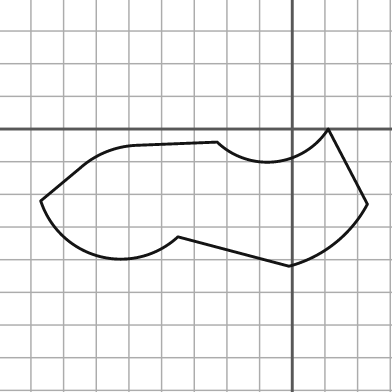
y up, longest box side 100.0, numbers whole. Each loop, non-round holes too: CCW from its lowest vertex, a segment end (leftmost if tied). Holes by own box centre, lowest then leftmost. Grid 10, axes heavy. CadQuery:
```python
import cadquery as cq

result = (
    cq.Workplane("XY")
    .moveTo(-1.0, -42.0)
    .threePointArc((13.0, -35.0), (23.0, -23.0))
    .lineTo(11.0, 0.0)
    .threePointArc((-5.0, -10.0), (-23.0, -4.0))
    .lineTo(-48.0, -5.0)
    .threePointArc((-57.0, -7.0), (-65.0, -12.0))
    .lineTo(-77.0, -22.0)
    .threePointArc((-59.0, -39.0), (-35.0, -33.0))
    .close()
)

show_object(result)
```